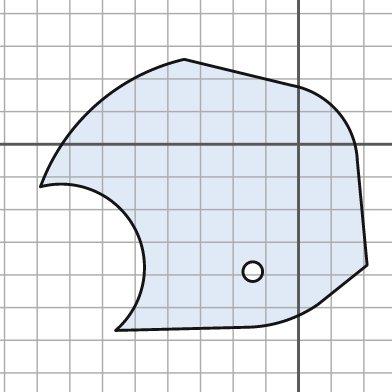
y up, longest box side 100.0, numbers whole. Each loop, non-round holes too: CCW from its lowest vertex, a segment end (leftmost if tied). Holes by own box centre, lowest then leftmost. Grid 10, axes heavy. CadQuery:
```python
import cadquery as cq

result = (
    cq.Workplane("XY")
    .moveTo(-56.0, -57.0)
    .lineTo(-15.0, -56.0)
    .threePointArc((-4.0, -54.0), (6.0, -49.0))
    .lineTo(21.0, -37.0)
    .lineTo(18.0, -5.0)
    .threePointArc((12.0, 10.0), (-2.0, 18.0))
    .lineTo(-35.0, 26.0)
    .threePointArc((-62.0, 12.0), (-79.0, -13.0))
    .threePointArc((-50.0, -26.0), (-56.0, -57.0))
    .close()
    .moveTo(-14.0, -39.0)
    .circle(3.0)
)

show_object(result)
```